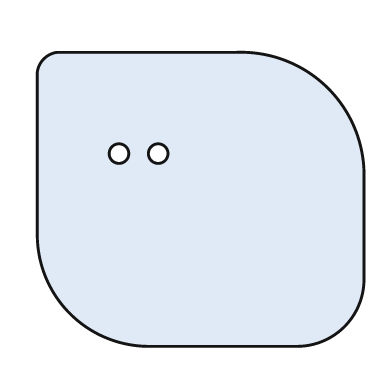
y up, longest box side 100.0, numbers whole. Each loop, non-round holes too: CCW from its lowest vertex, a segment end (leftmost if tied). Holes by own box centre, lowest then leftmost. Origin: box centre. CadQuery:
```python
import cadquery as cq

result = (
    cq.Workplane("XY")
    .moveTo(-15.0, -45.0)
    .lineTo(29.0, -45.0)
    .threePointArc((44.0, -39.0), (50.0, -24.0))
    .lineTo(50.0, 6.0)
    .threePointArc((39.0, 34.0), (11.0, 45.0))
    .lineTo(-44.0, 45.0)
    .threePointArc((-48.0, 43.0), (-50.0, 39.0))
    .lineTo(-50.0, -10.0)
    .threePointArc((-40.0, -35.0), (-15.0, -45.0))
    .close()
    .moveTo(-25.0, 14.0)
    .circle(3.0)
    .moveTo(-13.0, 14.0)
    .circle(3.0)
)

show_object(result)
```